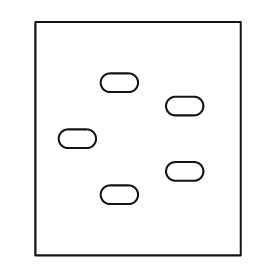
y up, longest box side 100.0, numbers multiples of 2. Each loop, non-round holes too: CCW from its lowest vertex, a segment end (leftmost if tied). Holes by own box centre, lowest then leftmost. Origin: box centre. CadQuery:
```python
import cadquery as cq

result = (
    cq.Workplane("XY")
    .moveTo(-44.0, -50.0)
    .lineTo(44.0, -50.0)
    .lineTo(44.0, 50.0)
    .lineTo(-44.0, 50.0)
    .close()
    .moveTo(-12.0, -28.0)
    .lineTo(-4.0, -28.0)
    .threePointArc((0.0, -24.0), (-4.0, -20.0))
    .lineTo(-12.0, -20.0)
    .threePointArc((-16.0, -24.0), (-12.0, -28.0))
    .close()
    .moveTo(16.0, -18.0)
    .lineTo(24.0, -18.0)
    .threePointArc((28.0, -14.0), (24.0, -10.0))
    .lineTo(16.0, -10.0)
    .threePointArc((12.0, -14.0), (16.0, -18.0))
    .close()
    .moveTo(-30.0, -4.0)
    .lineTo(-22.0, -4.0)
    .threePointArc((-18.0, 0.0), (-22.0, 4.0))
    .lineTo(-30.0, 4.0)
    .threePointArc((-34.0, 0.0), (-30.0, -4.0))
    .close()
    .moveTo(16.0, 10.0)
    .lineTo(24.0, 10.0)
    .threePointArc((28.0, 14.0), (24.0, 18.0))
    .lineTo(16.0, 18.0)
    .threePointArc((12.0, 14.0), (16.0, 10.0))
    .close()
    .moveTo(-12.0, 20.0)
    .lineTo(-4.0, 20.0)
    .threePointArc((0.0, 24.0), (-4.0, 28.0))
    .lineTo(-12.0, 28.0)
    .threePointArc((-16.0, 24.0), (-12.0, 20.0))
    .close()
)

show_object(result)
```